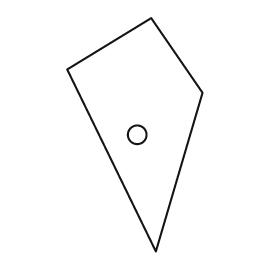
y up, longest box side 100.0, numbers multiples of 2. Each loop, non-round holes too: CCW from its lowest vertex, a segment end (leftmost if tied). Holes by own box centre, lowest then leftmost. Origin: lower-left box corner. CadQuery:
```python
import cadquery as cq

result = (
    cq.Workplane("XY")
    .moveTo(38.0, 0.0)
    .lineTo(58.0, 68.0)
    .lineTo(36.0, 100.0)
    .lineTo(0.0, 78.0)
    .close()
    .moveTo(30.0, 50.0)
    .circle(4.0)
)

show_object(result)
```